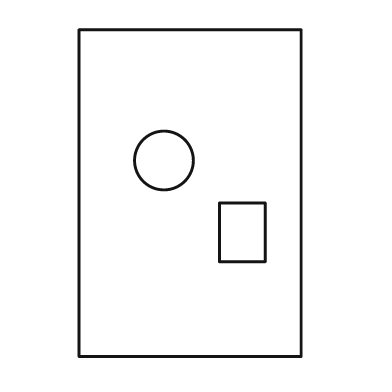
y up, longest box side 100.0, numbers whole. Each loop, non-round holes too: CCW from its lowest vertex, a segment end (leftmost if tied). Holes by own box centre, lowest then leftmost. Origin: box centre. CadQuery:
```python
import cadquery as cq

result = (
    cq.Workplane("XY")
    .moveTo(-34.0, -50.0)
    .lineTo(34.0, -50.0)
    .lineTo(34.0, 50.0)
    .lineTo(-34.0, 50.0)
    .close()
    .moveTo(9.0, -21.0)
    .lineTo(23.0, -21.0)
    .lineTo(23.0, -3.0)
    .lineTo(9.0, -3.0)
    .close()
    .moveTo(-8.0, 10.0)
    .circle(9.0)
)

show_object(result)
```